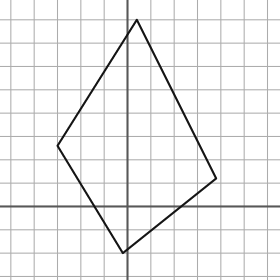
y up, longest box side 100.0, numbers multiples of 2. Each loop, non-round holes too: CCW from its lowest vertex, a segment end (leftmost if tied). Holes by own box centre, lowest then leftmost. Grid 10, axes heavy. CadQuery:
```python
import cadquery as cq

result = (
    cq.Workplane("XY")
    .moveTo(-2.0, -20.0)
    .lineTo(38.0, 12.0)
    .lineTo(4.0, 80.0)
    .lineTo(-30.0, 26.0)
    .close()
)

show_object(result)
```